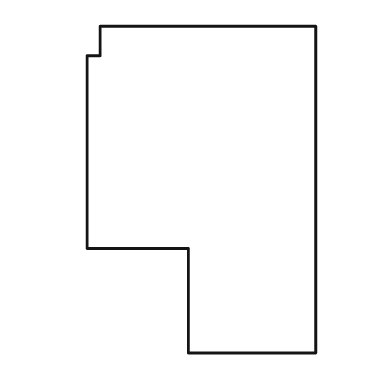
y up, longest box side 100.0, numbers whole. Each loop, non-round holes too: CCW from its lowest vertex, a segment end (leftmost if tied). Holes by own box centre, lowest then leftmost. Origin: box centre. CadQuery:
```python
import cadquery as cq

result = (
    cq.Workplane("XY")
    .moveTo(-4.0, -50.0)
    .lineTo(35.0, -50.0)
    .lineTo(35.0, 50.0)
    .lineTo(-31.0, 50.0)
    .lineTo(-31.0, 41.0)
    .lineTo(-35.0, 41.0)
    .lineTo(-35.0, -18.0)
    .lineTo(-4.0, -18.0)
    .close()
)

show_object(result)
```